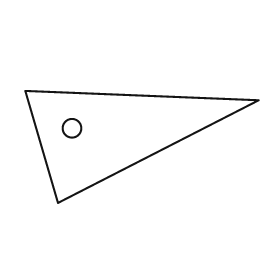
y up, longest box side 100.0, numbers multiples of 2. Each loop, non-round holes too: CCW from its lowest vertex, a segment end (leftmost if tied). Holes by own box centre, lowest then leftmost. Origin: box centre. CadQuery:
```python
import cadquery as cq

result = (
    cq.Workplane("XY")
    .moveTo(-36.0, -24.0)
    .lineTo(50.0, 20.0)
    .lineTo(-50.0, 24.0)
    .close()
    .moveTo(-30.0, 8.0)
    .circle(4.0)
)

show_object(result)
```